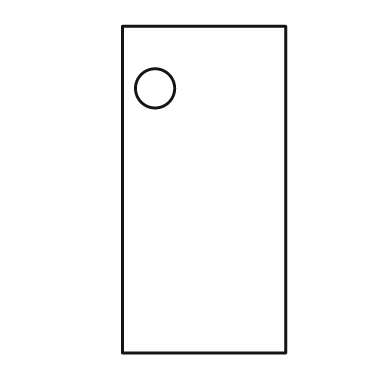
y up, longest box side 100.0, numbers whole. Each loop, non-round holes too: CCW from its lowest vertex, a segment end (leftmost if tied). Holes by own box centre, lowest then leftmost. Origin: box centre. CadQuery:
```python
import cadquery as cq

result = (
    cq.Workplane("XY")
    .moveTo(-25.0, -50.0)
    .lineTo(25.0, -50.0)
    .lineTo(25.0, 50.0)
    .lineTo(-25.0, 50.0)
    .close()
    .moveTo(-15.0, 31.0)
    .circle(6.0)
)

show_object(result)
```